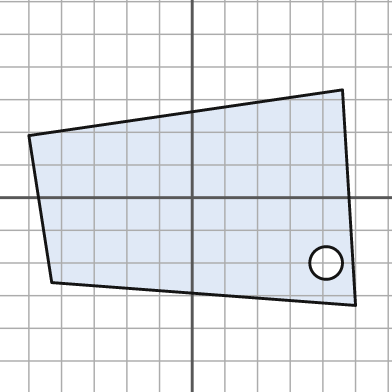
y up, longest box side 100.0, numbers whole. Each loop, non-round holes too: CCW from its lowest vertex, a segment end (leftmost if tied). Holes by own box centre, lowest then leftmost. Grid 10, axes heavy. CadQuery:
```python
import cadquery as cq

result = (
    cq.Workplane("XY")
    .moveTo(50.0, -33.0)
    .lineTo(46.0, 33.0)
    .lineTo(-50.0, 19.0)
    .lineTo(-43.0, -26.0)
    .close()
    .moveTo(41.0, -20.0)
    .circle(5.0)
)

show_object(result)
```